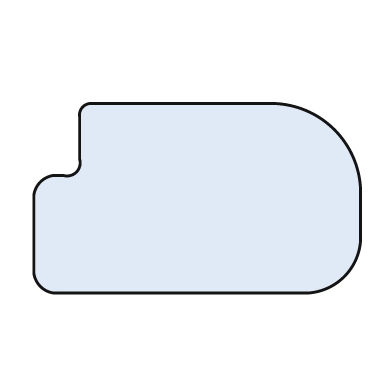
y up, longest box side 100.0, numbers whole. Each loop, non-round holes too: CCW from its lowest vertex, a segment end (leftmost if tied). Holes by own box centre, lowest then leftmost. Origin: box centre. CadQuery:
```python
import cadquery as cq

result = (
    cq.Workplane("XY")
    .moveTo(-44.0, -29.0)
    .lineTo(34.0, -29.0)
    .threePointArc((45.0, -24.0), (50.0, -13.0))
    .lineTo(50.0, 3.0)
    .threePointArc((42.0, 21.0), (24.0, 29.0))
    .lineTo(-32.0, 29.0)
    .threePointArc((-35.0, 28.0), (-36.0, 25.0))
    .lineTo(-36.0, 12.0)
    .threePointArc((-37.0, 8.0), (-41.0, 7.0))
    .lineTo(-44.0, 7.0)
    .threePointArc((-48.0, 5.0), (-50.0, 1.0))
    .lineTo(-50.0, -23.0)
    .threePointArc((-48.0, -27.0), (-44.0, -29.0))
    .close()
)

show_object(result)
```